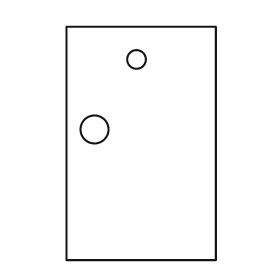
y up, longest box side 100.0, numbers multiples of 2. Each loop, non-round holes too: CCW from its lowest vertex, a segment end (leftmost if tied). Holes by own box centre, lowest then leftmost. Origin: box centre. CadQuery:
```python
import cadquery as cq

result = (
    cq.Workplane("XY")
    .moveTo(-32.0, -50.0)
    .lineTo(32.0, -50.0)
    .lineTo(32.0, 50.0)
    .lineTo(-32.0, 50.0)
    .close()
    .moveTo(-20.0, 6.0)
    .circle(6.0)
    .moveTo(-2.0, 36.0)
    .circle(4.0)
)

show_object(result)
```